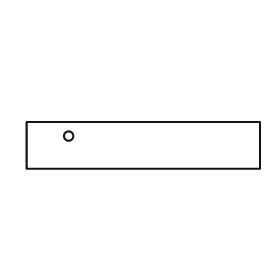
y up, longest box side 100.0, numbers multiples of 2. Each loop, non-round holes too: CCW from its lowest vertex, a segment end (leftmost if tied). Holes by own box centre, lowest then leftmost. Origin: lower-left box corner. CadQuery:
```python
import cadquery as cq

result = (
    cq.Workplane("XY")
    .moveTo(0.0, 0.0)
    .lineTo(100.0, 0.0)
    .lineTo(100.0, 20.0)
    .lineTo(0.0, 20.0)
    .close()
    .moveTo(18.0, 14.0)
    .circle(2.0)
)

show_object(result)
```